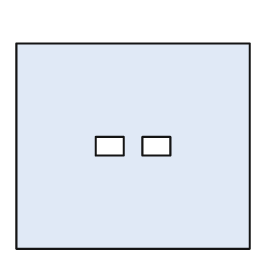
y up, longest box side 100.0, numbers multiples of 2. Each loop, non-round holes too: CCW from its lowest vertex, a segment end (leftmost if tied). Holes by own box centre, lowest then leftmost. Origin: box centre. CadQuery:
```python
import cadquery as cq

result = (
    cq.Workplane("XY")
    .moveTo(-50.0, -44.0)
    .lineTo(50.0, -44.0)
    .lineTo(50.0, 44.0)
    .lineTo(-50.0, 44.0)
    .close()
    .moveTo(-16.0, -4.0)
    .lineTo(-4.0, -4.0)
    .lineTo(-4.0, 4.0)
    .lineTo(-16.0, 4.0)
    .close()
    .moveTo(4.0, -4.0)
    .lineTo(16.0, -4.0)
    .lineTo(16.0, 4.0)
    .lineTo(4.0, 4.0)
    .close()
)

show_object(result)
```